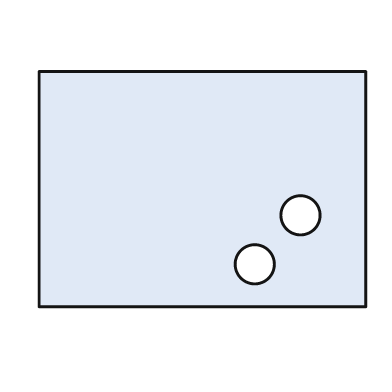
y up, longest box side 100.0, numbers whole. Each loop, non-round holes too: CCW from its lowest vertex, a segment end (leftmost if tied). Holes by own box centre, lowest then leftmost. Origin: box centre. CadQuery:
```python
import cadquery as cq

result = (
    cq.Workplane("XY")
    .moveTo(-50.0, -36.0)
    .lineTo(50.0, -36.0)
    .lineTo(50.0, 36.0)
    .lineTo(-50.0, 36.0)
    .close()
    .moveTo(16.0, -23.0)
    .circle(6.0)
    .moveTo(30.0, -8.0)
    .circle(6.0)
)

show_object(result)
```